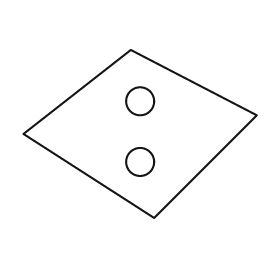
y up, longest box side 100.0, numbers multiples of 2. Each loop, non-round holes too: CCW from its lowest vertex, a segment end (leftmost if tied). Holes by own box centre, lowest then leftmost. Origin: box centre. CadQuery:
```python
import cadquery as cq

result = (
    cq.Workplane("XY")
    .moveTo(6.0, -36.0)
    .lineTo(50.0, 8.0)
    .lineTo(-4.0, 36.0)
    .lineTo(-50.0, 0.0)
    .close()
    .moveTo(0.0, -12.0)
    .circle(6.0)
    .moveTo(0.0, 14.0)
    .circle(6.0)
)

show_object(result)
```